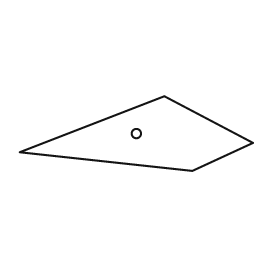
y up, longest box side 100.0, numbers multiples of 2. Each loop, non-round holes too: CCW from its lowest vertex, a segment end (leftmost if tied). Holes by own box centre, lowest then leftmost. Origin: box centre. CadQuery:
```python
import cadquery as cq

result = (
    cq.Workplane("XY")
    .moveTo(24.0, -16.0)
    .lineTo(50.0, -4.0)
    .lineTo(12.0, 16.0)
    .lineTo(-50.0, -8.0)
    .close()
    .moveTo(0.0, 0.0)
    .circle(2.0)
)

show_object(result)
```